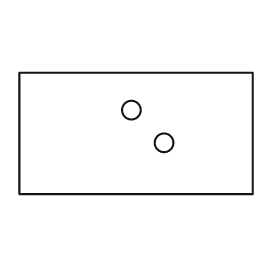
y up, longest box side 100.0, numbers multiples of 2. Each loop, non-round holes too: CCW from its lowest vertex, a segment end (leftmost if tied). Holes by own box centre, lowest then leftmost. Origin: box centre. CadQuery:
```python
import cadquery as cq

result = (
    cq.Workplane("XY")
    .moveTo(-50.0, -26.0)
    .lineTo(50.0, -26.0)
    .lineTo(50.0, 26.0)
    .lineTo(-50.0, 26.0)
    .close()
    .moveTo(12.0, -4.0)
    .circle(4.0)
    .moveTo(-2.0, 10.0)
    .circle(4.0)
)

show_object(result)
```